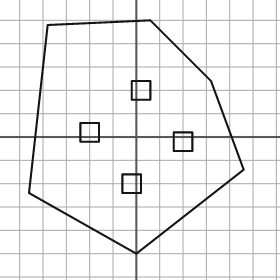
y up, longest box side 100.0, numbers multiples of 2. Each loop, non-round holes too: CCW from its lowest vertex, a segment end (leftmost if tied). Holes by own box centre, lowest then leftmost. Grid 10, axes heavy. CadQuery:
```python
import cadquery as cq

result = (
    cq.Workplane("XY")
    .moveTo(0.0, -50.0)
    .lineTo(46.0, -14.0)
    .lineTo(32.0, 24.0)
    .lineTo(6.0, 50.0)
    .lineTo(-38.0, 48.0)
    .lineTo(-46.0, -24.0)
    .close()
    .moveTo(-6.0, -24.0)
    .lineTo(2.0, -24.0)
    .lineTo(2.0, -16.0)
    .lineTo(-6.0, -16.0)
    .close()
    .moveTo(16.0, -6.0)
    .lineTo(24.0, -6.0)
    .lineTo(24.0, 2.0)
    .lineTo(16.0, 2.0)
    .close()
    .moveTo(-24.0, -2.0)
    .lineTo(-16.0, -2.0)
    .lineTo(-16.0, 6.0)
    .lineTo(-24.0, 6.0)
    .close()
    .moveTo(-2.0, 16.0)
    .lineTo(6.0, 16.0)
    .lineTo(6.0, 24.0)
    .lineTo(-2.0, 24.0)
    .close()
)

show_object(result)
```